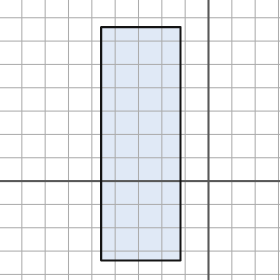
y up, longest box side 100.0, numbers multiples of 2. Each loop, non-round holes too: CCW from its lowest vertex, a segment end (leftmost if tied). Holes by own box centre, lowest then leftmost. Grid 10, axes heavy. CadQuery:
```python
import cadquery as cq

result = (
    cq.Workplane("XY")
    .moveTo(-46.0, -34.0)
    .lineTo(-12.0, -34.0)
    .lineTo(-12.0, 66.0)
    .lineTo(-46.0, 66.0)
    .close()
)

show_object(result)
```